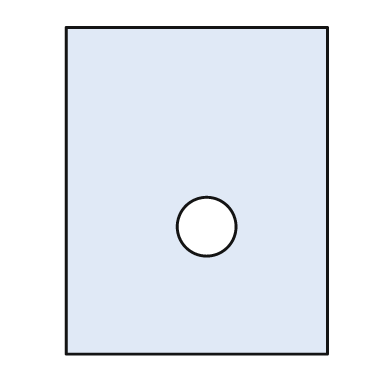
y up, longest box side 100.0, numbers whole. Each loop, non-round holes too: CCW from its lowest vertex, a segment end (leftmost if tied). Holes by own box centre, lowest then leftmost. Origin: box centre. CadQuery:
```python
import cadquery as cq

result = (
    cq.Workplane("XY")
    .moveTo(-40.0, -50.0)
    .lineTo(40.0, -50.0)
    .lineTo(40.0, 50.0)
    .lineTo(-40.0, 50.0)
    .close()
    .moveTo(3.0, -11.0)
    .circle(9.0)
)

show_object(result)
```